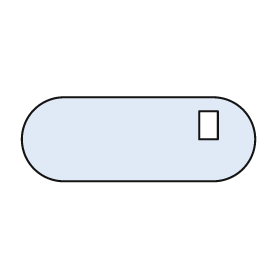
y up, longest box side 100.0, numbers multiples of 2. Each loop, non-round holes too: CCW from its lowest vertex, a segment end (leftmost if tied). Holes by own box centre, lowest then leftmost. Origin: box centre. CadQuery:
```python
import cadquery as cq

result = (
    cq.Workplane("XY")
    .moveTo(-32.0, -18.0)
    .lineTo(32.0, -18.0)
    .threePointArc((50.0, 0.0), (32.0, 18.0))
    .lineTo(-32.0, 18.0)
    .threePointArc((-50.0, 0.0), (-32.0, -18.0))
    .close()
    .moveTo(26.0, 0.0)
    .lineTo(34.0, 0.0)
    .lineTo(34.0, 12.0)
    .lineTo(26.0, 12.0)
    .close()
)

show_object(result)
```